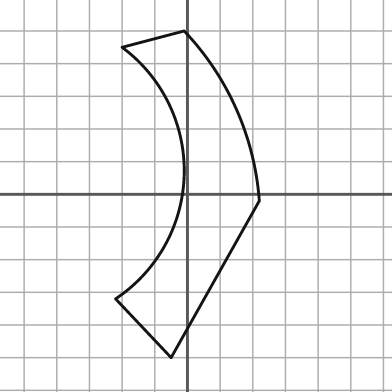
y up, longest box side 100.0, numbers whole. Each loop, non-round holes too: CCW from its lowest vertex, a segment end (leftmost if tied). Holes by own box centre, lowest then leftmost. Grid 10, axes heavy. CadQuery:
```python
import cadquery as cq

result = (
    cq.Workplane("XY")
    .moveTo(-5.0, -50.0)
    .lineTo(22.0, -2.0)
    .threePointArc((15.0, 26.0), (-1.0, 50.0))
    .lineTo(-20.0, 45.0)
    .threePointArc((-1.0, 6.0), (-22.0, -32.0))
    .close()
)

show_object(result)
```